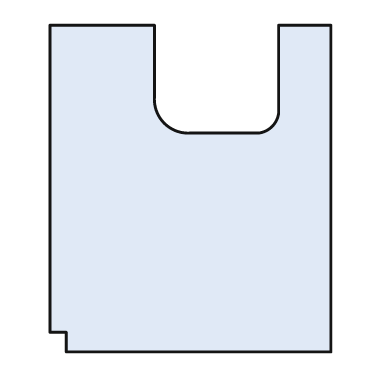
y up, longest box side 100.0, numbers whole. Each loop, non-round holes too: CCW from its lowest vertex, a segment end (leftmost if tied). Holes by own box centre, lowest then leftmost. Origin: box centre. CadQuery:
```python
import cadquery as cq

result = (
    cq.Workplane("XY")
    .moveTo(-38.0, -50.0)
    .lineTo(43.0, -50.0)
    .lineTo(43.0, 50.0)
    .lineTo(27.0, 50.0)
    .lineTo(27.0, 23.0)
    .threePointArc((25.0, 19.0), (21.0, 17.0))
    .lineTo(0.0, 17.0)
    .threePointArc((-8.0, 20.0), (-11.0, 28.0))
    .lineTo(-11.0, 50.0)
    .lineTo(-43.0, 50.0)
    .lineTo(-43.0, -44.0)
    .lineTo(-38.0, -44.0)
    .close()
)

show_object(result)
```